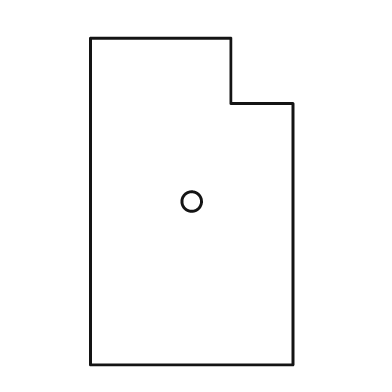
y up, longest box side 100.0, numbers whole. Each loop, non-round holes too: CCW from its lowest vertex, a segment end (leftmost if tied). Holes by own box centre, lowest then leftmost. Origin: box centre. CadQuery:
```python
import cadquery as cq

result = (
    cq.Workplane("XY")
    .moveTo(-31.0, -50.0)
    .lineTo(31.0, -50.0)
    .lineTo(31.0, 30.0)
    .lineTo(12.0, 30.0)
    .lineTo(12.0, 50.0)
    .lineTo(-31.0, 50.0)
    .close()
    .moveTo(0.0, 0.0)
    .circle(3.0)
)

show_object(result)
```